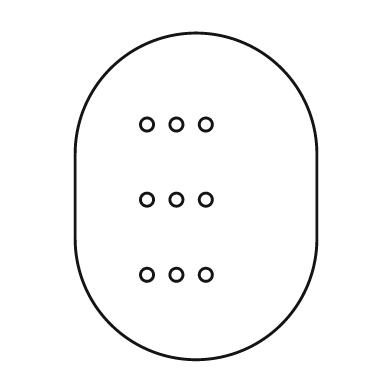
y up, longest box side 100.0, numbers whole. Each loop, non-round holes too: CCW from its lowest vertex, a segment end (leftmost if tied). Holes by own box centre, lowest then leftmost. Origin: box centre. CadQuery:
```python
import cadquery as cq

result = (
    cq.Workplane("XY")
    .moveTo(-37.0, -13.0)
    .threePointArc((0.0, -50.0), (37.0, -13.0))
    .lineTo(37.0, 13.0)
    .threePointArc((0.0, 50.0), (-37.0, 13.0))
    .close()
    .moveTo(-15.0, -24.0)
    .circle(2.0)
    .moveTo(-6.0, -24.0)
    .circle(2.0)
    .moveTo(3.0, -24.0)
    .circle(2.0)
    .moveTo(-15.0, -1.0)
    .circle(2.0)
    .moveTo(-6.0, -1.0)
    .circle(2.0)
    .moveTo(3.0, -1.0)
    .circle(2.0)
    .moveTo(-15.0, 22.0)
    .circle(2.0)
    .moveTo(-6.0, 22.0)
    .circle(2.0)
    .moveTo(3.0, 22.0)
    .circle(2.0)
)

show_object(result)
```